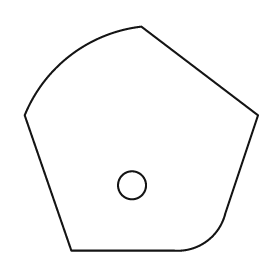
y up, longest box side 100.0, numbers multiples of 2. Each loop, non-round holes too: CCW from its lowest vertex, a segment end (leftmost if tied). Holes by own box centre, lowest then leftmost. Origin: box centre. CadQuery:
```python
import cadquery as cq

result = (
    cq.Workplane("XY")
    .moveTo(-30.0, -48.0)
    .lineTo(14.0, -48.0)
    .threePointArc((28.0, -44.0), (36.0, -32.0))
    .lineTo(50.0, 10.0)
    .lineTo(0.0, 48.0)
    .threePointArc((-30.0, 36.0), (-50.0, 10.0))
    .close()
    .moveTo(-4.0, -20.0)
    .circle(6.0)
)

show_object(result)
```